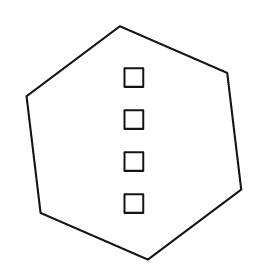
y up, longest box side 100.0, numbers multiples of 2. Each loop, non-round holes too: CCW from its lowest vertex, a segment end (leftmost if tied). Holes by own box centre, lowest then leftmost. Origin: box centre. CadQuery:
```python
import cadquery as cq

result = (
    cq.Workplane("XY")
    .moveTo(6.0, -50.0)
    .lineTo(46.0, -20.0)
    .lineTo(40.0, 30.0)
    .lineTo(-6.0, 50.0)
    .lineTo(-46.0, 20.0)
    .lineTo(-40.0, -30.0)
    .close()
    .moveTo(-4.0, -30.0)
    .lineTo(4.0, -30.0)
    .lineTo(4.0, -22.0)
    .lineTo(-4.0, -22.0)
    .close()
    .moveTo(-4.0, -12.0)
    .lineTo(4.0, -12.0)
    .lineTo(4.0, -4.0)
    .lineTo(-4.0, -4.0)
    .close()
    .moveTo(-4.0, 6.0)
    .lineTo(4.0, 6.0)
    .lineTo(4.0, 14.0)
    .lineTo(-4.0, 14.0)
    .close()
    .moveTo(-4.0, 24.0)
    .lineTo(4.0, 24.0)
    .lineTo(4.0, 32.0)
    .lineTo(-4.0, 32.0)
    .close()
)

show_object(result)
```